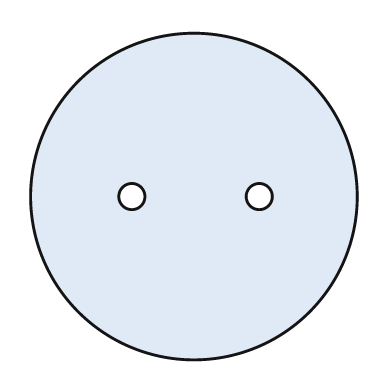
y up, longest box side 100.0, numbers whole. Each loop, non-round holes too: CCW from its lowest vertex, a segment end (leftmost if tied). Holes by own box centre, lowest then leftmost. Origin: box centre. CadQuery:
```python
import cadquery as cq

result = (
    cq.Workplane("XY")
    .moveTo(0.0, 0.0)
    .circle(50.0)
    .moveTo(-19.0, 0.0)
    .circle(4.0)
    .moveTo(20.0, 0.0)
    .circle(4.0)
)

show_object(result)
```